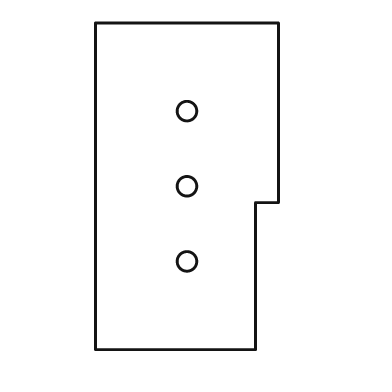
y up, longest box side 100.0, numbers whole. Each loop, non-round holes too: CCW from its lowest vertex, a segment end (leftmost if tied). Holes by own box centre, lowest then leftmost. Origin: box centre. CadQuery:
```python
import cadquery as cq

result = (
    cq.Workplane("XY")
    .moveTo(-28.0, -50.0)
    .lineTo(21.0, -50.0)
    .lineTo(21.0, -5.0)
    .lineTo(28.0, -5.0)
    .lineTo(28.0, 50.0)
    .lineTo(-28.0, 50.0)
    .close()
    .moveTo(0.0, -23.0)
    .circle(3.0)
    .moveTo(0.0, 0.0)
    .circle(3.0)
    .moveTo(0.0, 23.0)
    .circle(3.0)
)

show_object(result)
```